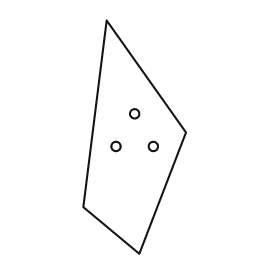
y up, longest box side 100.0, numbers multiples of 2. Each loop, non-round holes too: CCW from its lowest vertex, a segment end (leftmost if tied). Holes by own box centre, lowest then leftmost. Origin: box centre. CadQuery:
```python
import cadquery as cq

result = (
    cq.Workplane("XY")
    .moveTo(2.0, -50.0)
    .lineTo(22.0, 2.0)
    .lineTo(-12.0, 50.0)
    .lineTo(-22.0, -30.0)
    .close()
    .moveTo(-8.0, -4.0)
    .circle(2.0)
    .moveTo(8.0, -4.0)
    .circle(2.0)
    .moveTo(0.0, 10.0)
    .circle(2.0)
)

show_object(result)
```